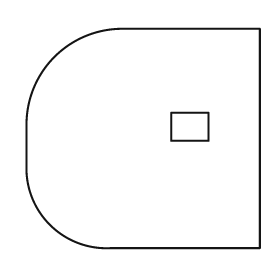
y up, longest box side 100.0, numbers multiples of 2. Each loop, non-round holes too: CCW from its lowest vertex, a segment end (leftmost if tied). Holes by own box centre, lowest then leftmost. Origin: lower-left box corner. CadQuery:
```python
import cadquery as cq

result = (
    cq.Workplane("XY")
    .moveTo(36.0, 0.0)
    .lineTo(100.0, 0.0)
    .lineTo(100.0, 94.0)
    .lineTo(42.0, 94.0)
    .threePointArc((12.0, 82.0), (0.0, 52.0))
    .lineTo(0.0, 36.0)
    .threePointArc((10.0, 10.0), (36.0, 0.0))
    .close()
    .moveTo(62.0, 46.0)
    .lineTo(78.0, 46.0)
    .lineTo(78.0, 58.0)
    .lineTo(62.0, 58.0)
    .close()
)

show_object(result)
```